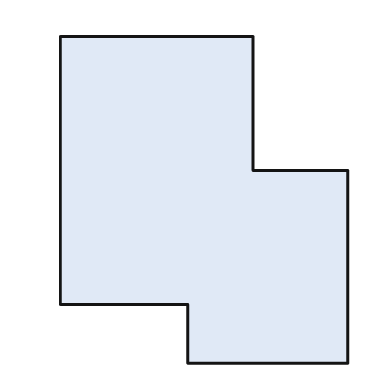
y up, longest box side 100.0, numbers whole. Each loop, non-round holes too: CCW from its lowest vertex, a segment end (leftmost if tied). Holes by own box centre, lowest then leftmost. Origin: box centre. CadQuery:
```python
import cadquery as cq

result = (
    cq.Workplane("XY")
    .moveTo(-5.0, -50.0)
    .lineTo(44.0, -50.0)
    .lineTo(44.0, 9.0)
    .lineTo(15.0, 9.0)
    .lineTo(15.0, 50.0)
    .lineTo(-44.0, 50.0)
    .lineTo(-44.0, -32.0)
    .lineTo(-5.0, -32.0)
    .close()
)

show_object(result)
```